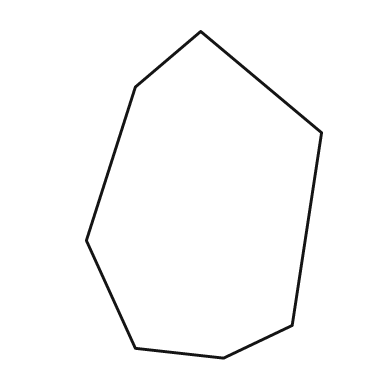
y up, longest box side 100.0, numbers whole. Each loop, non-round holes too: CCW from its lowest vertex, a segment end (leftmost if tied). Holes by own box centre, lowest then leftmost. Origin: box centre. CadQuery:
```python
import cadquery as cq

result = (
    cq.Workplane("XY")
    .moveTo(6.0, -50.0)
    .lineTo(27.0, -40.0)
    .lineTo(36.0, 19.0)
    .lineTo(-1.0, 50.0)
    .lineTo(-21.0, 33.0)
    .lineTo(-36.0, -14.0)
    .lineTo(-21.0, -47.0)
    .close()
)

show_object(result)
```